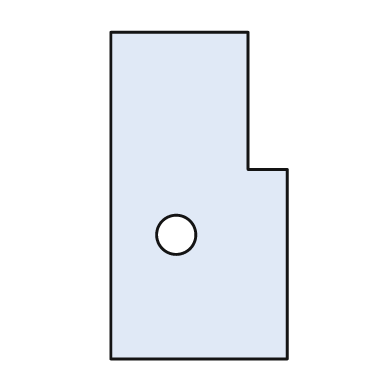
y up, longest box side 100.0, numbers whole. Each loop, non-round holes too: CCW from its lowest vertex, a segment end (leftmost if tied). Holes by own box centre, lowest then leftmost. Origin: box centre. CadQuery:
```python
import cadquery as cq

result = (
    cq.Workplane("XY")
    .moveTo(-27.0, -50.0)
    .lineTo(27.0, -50.0)
    .lineTo(27.0, 8.0)
    .lineTo(15.0, 8.0)
    .lineTo(15.0, 50.0)
    .lineTo(-27.0, 50.0)
    .close()
    .moveTo(-7.0, -12.0)
    .circle(6.0)
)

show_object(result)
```